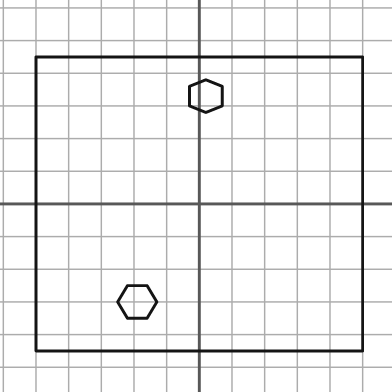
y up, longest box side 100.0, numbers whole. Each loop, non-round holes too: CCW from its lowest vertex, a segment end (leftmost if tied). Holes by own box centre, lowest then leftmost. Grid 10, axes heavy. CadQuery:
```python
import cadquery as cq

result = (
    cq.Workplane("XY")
    .moveTo(-50.0, -45.0)
    .lineTo(50.0, -45.0)
    .lineTo(50.0, 45.0)
    .lineTo(-50.0, 45.0)
    .close()
    .moveTo(-22.0, -35.0)
    .lineTo(-16.0, -35.0)
    .lineTo(-13.0, -30.0)
    .lineTo(-16.0, -25.0)
    .lineTo(-22.0, -25.0)
    .lineTo(-25.0, -30.0)
    .close()
    .moveTo(2.0, 28.0)
    .lineTo(7.0, 30.0)
    .lineTo(7.0, 36.0)
    .lineTo(2.0, 38.0)
    .lineTo(-3.0, 36.0)
    .lineTo(-3.0, 30.0)
    .close()
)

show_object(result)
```